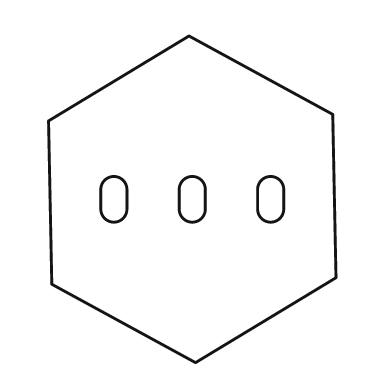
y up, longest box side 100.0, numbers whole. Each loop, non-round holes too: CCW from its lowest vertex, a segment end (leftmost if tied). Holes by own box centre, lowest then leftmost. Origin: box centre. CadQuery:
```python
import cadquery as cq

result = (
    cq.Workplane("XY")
    .moveTo(1.0, -50.0)
    .lineTo(44.0, -24.0)
    .lineTo(43.0, 26.0)
    .lineTo(-1.0, 50.0)
    .lineTo(-44.0, 24.0)
    .lineTo(-43.0, -26.0)
    .close()
    .moveTo(-28.0, -3.0)
    .threePointArc((-24.0, -7.0), (-20.0, -3.0))
    .lineTo(-20.0, 3.0)
    .threePointArc((-24.0, 7.0), (-28.0, 3.0))
    .close()
    .moveTo(-4.0, -3.0)
    .threePointArc((0.0, -7.0), (4.0, -3.0))
    .lineTo(4.0, 3.0)
    .threePointArc((0.0, 7.0), (-4.0, 3.0))
    .close()
    .moveTo(20.0, -3.0)
    .threePointArc((24.0, -7.0), (28.0, -3.0))
    .lineTo(28.0, 3.0)
    .threePointArc((24.0, 7.0), (20.0, 3.0))
    .close()
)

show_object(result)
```